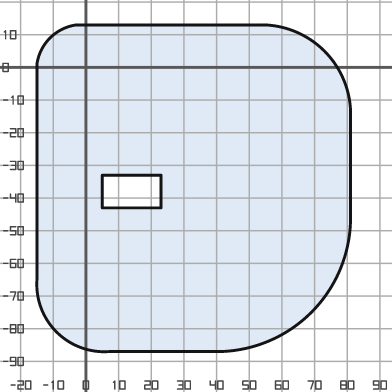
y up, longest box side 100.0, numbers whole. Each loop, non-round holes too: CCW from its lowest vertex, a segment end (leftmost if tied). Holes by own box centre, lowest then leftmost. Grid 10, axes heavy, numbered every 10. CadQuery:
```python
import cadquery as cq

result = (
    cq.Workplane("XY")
    .moveTo(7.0, -87.0)
    .lineTo(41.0, -87.0)
    .threePointArc((69.0, -75.0), (81.0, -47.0))
    .lineTo(81.0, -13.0)
    .threePointArc((73.0, 5.0), (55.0, 13.0))
    .lineTo(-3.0, 13.0)
    .threePointArc((-11.0, 9.0), (-15.0, 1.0))
    .lineTo(-15.0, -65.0)
    .threePointArc((-9.0, -81.0), (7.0, -87.0))
    .close()
    .moveTo(5.0, -43.0)
    .lineTo(23.0, -43.0)
    .lineTo(23.0, -33.0)
    .lineTo(5.0, -33.0)
    .close()
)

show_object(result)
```